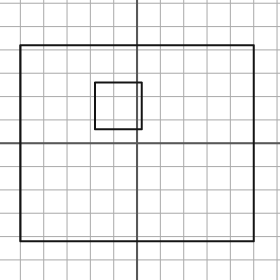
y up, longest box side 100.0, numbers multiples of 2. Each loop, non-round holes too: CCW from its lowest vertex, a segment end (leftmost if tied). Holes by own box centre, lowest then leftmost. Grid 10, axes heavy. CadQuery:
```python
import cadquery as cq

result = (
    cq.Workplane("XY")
    .moveTo(-50.0, -42.0)
    .lineTo(50.0, -42.0)
    .lineTo(50.0, 42.0)
    .lineTo(-50.0, 42.0)
    .close()
    .moveTo(-18.0, 6.0)
    .lineTo(2.0, 6.0)
    .lineTo(2.0, 26.0)
    .lineTo(-18.0, 26.0)
    .close()
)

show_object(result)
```